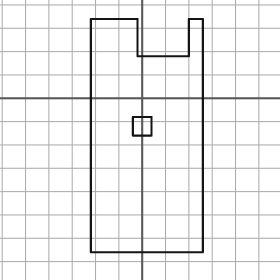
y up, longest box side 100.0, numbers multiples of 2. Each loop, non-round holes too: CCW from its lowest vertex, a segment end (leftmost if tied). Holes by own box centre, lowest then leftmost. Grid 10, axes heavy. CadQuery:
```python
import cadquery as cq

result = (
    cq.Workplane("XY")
    .moveTo(-22.0, -66.0)
    .lineTo(26.0, -66.0)
    .lineTo(26.0, 34.0)
    .lineTo(20.0, 34.0)
    .lineTo(20.0, 18.0)
    .lineTo(-2.0, 18.0)
    .lineTo(-2.0, 34.0)
    .lineTo(-22.0, 34.0)
    .close()
    .moveTo(-4.0, -16.0)
    .lineTo(4.0, -16.0)
    .lineTo(4.0, -8.0)
    .lineTo(-4.0, -8.0)
    .close()
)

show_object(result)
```